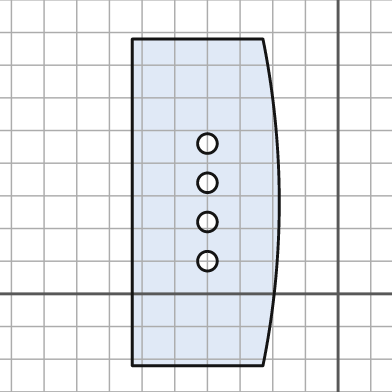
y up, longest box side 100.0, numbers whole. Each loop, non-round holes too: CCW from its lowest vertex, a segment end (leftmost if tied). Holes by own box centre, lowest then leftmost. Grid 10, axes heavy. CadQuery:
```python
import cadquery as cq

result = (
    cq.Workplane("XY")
    .moveTo(-63.0, -22.0)
    .lineTo(-23.0, -22.0)
    .threePointArc((-18.0, 28.0), (-23.0, 78.0))
    .lineTo(-63.0, 78.0)
    .close()
    .moveTo(-40.0, 10.0)
    .circle(3.0)
    .moveTo(-40.0, 22.0)
    .circle(3.0)
    .moveTo(-40.0, 34.0)
    .circle(3.0)
    .moveTo(-40.0, 46.0)
    .circle(3.0)
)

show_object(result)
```